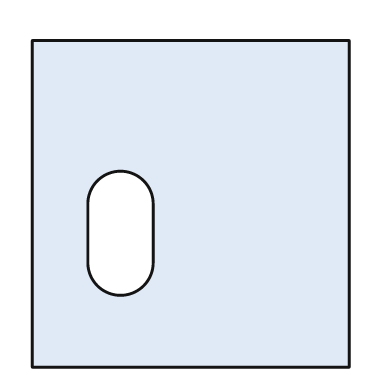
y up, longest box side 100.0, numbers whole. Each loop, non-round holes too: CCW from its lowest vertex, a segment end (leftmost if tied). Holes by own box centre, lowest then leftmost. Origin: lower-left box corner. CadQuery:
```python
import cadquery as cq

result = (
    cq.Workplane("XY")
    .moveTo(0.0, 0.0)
    .lineTo(97.0, 0.0)
    .lineTo(97.0, 100.0)
    .lineTo(0.0, 100.0)
    .close()
    .moveTo(17.0, 32.0)
    .threePointArc((27.0, 22.0), (37.0, 32.0))
    .lineTo(37.0, 50.0)
    .threePointArc((27.0, 60.0), (17.0, 50.0))
    .close()
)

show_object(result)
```